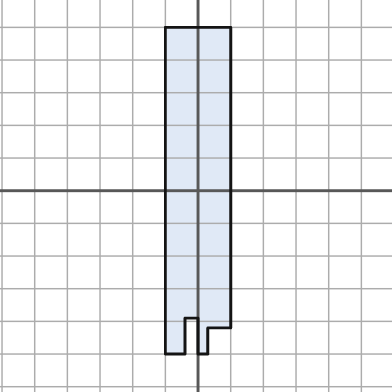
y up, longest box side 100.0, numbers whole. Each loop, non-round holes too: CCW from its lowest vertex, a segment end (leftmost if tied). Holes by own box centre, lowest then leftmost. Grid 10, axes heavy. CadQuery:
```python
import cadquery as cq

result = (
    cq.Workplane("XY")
    .moveTo(-10.0, -50.0)
    .lineTo(-4.0, -50.0)
    .lineTo(-4.0, -39.0)
    .lineTo(0.0, -39.0)
    .lineTo(0.0, -50.0)
    .lineTo(3.0, -50.0)
    .lineTo(3.0, -42.0)
    .lineTo(10.0, -42.0)
    .lineTo(10.0, 50.0)
    .lineTo(-10.0, 50.0)
    .close()
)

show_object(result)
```